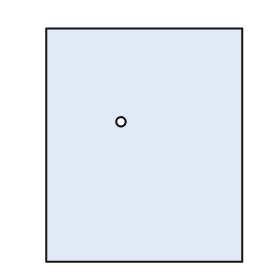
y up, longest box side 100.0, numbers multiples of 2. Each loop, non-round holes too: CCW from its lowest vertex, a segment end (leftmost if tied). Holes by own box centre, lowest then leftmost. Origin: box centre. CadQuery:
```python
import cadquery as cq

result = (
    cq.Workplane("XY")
    .moveTo(-42.0, -50.0)
    .lineTo(42.0, -50.0)
    .lineTo(42.0, 50.0)
    .lineTo(-42.0, 50.0)
    .close()
    .moveTo(-10.0, 10.0)
    .circle(2.0)
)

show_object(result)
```